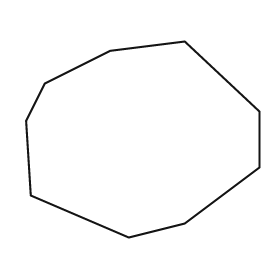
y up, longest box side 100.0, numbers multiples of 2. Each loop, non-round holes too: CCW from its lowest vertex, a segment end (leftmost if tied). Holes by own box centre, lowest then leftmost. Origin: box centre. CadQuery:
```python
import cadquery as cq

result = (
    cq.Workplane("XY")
    .moveTo(-6.0, -42.0)
    .lineTo(18.0, -36.0)
    .lineTo(50.0, -12.0)
    .lineTo(50.0, 12.0)
    .lineTo(18.0, 42.0)
    .lineTo(-14.0, 38.0)
    .lineTo(-42.0, 24.0)
    .lineTo(-50.0, 8.0)
    .lineTo(-48.0, -24.0)
    .close()
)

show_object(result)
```